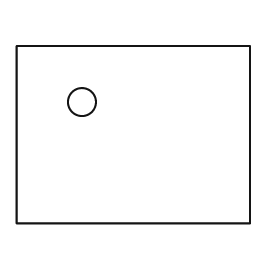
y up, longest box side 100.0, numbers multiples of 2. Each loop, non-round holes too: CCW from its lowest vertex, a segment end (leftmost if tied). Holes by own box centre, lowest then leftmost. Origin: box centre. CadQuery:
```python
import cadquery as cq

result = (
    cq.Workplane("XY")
    .moveTo(-50.0, -38.0)
    .lineTo(50.0, -38.0)
    .lineTo(50.0, 38.0)
    .lineTo(-50.0, 38.0)
    .close()
    .moveTo(-22.0, 14.0)
    .circle(6.0)
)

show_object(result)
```